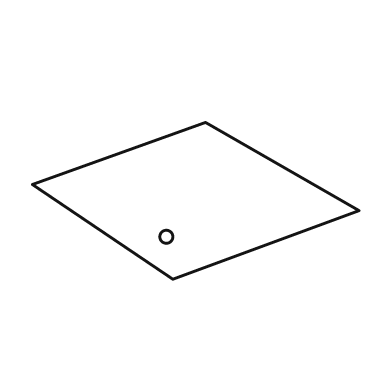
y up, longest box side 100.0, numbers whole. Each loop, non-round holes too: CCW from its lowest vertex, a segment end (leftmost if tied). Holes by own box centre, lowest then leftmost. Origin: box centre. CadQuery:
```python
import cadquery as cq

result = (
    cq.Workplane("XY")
    .moveTo(-7.0, -24.0)
    .lineTo(50.0, -3.0)
    .lineTo(3.0, 24.0)
    .lineTo(-50.0, 5.0)
    .close()
    .moveTo(-9.0, -11.0)
    .circle(2.0)
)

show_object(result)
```